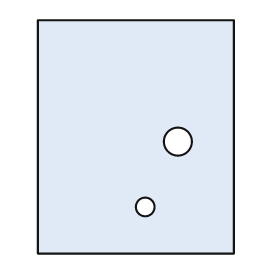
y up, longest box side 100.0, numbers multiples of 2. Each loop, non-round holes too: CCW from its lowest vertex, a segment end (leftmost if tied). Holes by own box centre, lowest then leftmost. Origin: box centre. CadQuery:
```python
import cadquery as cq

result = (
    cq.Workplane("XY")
    .moveTo(-42.0, -50.0)
    .lineTo(42.0, -50.0)
    .lineTo(42.0, 50.0)
    .lineTo(-42.0, 50.0)
    .close()
    .moveTo(4.0, -30.0)
    .circle(4.0)
    .moveTo(18.0, -2.0)
    .circle(6.0)
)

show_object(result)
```